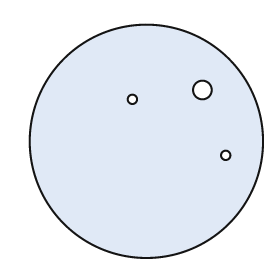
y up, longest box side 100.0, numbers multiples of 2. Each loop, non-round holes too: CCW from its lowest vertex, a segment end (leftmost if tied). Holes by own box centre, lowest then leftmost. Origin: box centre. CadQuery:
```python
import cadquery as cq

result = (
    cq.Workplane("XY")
    .moveTo(0.0, 0.0)
    .circle(50.0)
    .moveTo(34.0, -6.0)
    .circle(2.0)
    .moveTo(-6.0, 18.0)
    .circle(2.0)
    .moveTo(24.0, 22.0)
    .circle(4.0)
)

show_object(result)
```